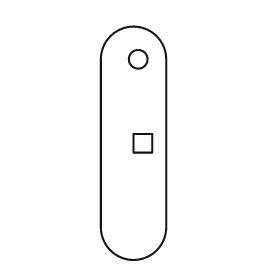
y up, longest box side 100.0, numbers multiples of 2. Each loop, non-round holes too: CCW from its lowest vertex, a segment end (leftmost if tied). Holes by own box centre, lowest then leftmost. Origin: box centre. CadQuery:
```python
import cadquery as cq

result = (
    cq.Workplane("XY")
    .moveTo(-14.0, -36.0)
    .threePointArc((0.0, -50.0), (14.0, -36.0))
    .lineTo(14.0, 36.0)
    .threePointArc((0.0, 50.0), (-14.0, 36.0))
    .close()
    .moveTo(0.0, -4.0)
    .lineTo(8.0, -4.0)
    .lineTo(8.0, 4.0)
    .lineTo(0.0, 4.0)
    .close()
    .moveTo(2.0, 36.0)
    .circle(4.0)
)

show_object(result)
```